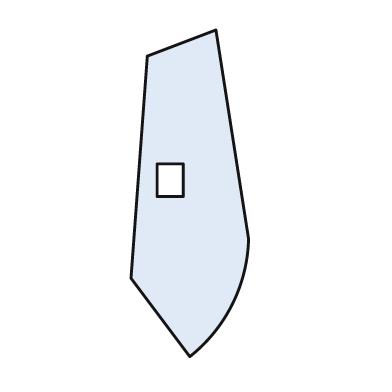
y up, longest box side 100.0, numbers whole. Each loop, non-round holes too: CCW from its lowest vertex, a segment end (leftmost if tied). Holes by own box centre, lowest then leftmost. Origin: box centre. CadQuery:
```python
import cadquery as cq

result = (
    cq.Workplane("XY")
    .moveTo(0.0, -50.0)
    .threePointArc((13.0, -34.0), (18.0, -14.0))
    .lineTo(8.0, 50.0)
    .lineTo(-13.0, 42.0)
    .lineTo(-18.0, -26.0)
    .close()
    .moveTo(-10.0, -1.0)
    .lineTo(-2.0, -1.0)
    .lineTo(-2.0, 9.0)
    .lineTo(-10.0, 9.0)
    .close()
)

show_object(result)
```